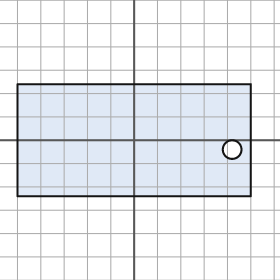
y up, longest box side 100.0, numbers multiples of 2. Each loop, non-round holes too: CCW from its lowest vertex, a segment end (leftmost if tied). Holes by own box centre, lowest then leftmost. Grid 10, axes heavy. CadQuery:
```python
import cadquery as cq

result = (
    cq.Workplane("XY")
    .moveTo(-50.0, -24.0)
    .lineTo(50.0, -24.0)
    .lineTo(50.0, 24.0)
    .lineTo(-50.0, 24.0)
    .close()
    .moveTo(42.0, -4.0)
    .circle(4.0)
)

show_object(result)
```